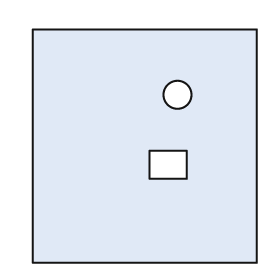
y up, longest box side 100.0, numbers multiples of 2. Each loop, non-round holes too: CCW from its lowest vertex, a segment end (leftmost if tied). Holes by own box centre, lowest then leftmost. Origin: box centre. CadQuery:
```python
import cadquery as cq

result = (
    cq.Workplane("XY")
    .moveTo(-48.0, -50.0)
    .lineTo(48.0, -50.0)
    .lineTo(48.0, 50.0)
    .lineTo(-48.0, 50.0)
    .close()
    .moveTo(2.0, -14.0)
    .lineTo(18.0, -14.0)
    .lineTo(18.0, -2.0)
    .lineTo(2.0, -2.0)
    .close()
    .moveTo(14.0, 22.0)
    .circle(6.0)
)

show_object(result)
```